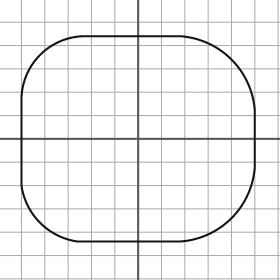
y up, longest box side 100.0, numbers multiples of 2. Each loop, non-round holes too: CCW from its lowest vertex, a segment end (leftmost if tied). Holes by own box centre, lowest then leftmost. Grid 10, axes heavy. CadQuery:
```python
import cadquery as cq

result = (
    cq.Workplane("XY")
    .moveTo(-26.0, -44.0)
    .lineTo(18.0, -44.0)
    .threePointArc((40.0, -34.0), (50.0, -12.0))
    .lineTo(50.0, 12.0)
    .threePointArc((40.0, 34.0), (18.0, 44.0))
    .lineTo(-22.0, 44.0)
    .threePointArc((-42.0, 36.0), (-50.0, 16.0))
    .lineTo(-50.0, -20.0)
    .threePointArc((-42.0, -36.0), (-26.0, -44.0))
    .close()
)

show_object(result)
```